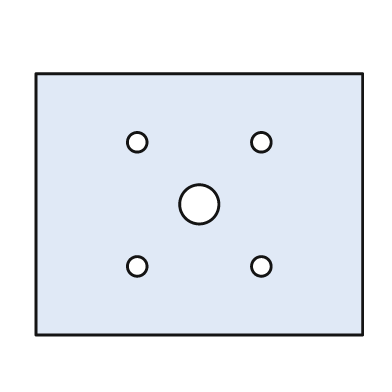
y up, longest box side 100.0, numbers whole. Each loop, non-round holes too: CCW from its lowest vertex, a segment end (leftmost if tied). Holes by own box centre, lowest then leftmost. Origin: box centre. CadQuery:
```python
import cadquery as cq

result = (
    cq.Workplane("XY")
    .moveTo(-50.0, -40.0)
    .lineTo(50.0, -40.0)
    .lineTo(50.0, 40.0)
    .lineTo(-50.0, 40.0)
    .close()
    .moveTo(-19.0, -19.0)
    .circle(3.0)
    .moveTo(19.0, -19.0)
    .circle(3.0)
    .moveTo(0.0, 0.0)
    .circle(6.0)
    .moveTo(-19.0, 19.0)
    .circle(3.0)
    .moveTo(19.0, 19.0)
    .circle(3.0)
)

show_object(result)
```